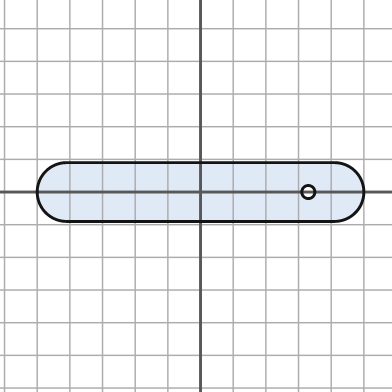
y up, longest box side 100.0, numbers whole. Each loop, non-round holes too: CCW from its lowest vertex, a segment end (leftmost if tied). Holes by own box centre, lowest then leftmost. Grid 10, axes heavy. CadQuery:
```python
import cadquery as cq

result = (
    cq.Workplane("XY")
    .moveTo(-41.0, -9.0)
    .lineTo(41.0, -9.0)
    .threePointArc((50.0, 0.0), (41.0, 9.0))
    .lineTo(-41.0, 9.0)
    .threePointArc((-50.0, 0.0), (-41.0, -9.0))
    .close()
    .moveTo(33.0, 0.0)
    .circle(2.0)
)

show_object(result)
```